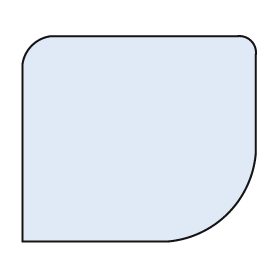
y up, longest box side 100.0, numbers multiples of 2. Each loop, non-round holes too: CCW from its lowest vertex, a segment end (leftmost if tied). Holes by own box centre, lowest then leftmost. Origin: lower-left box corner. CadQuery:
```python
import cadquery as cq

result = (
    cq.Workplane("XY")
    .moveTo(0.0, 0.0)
    .lineTo(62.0, 0.0)
    .threePointArc((88.0, 12.0), (100.0, 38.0))
    .lineTo(100.0, 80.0)
    .threePointArc((98.0, 86.0), (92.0, 88.0))
    .lineTo(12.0, 88.0)
    .threePointArc((4.0, 84.0), (0.0, 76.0))
    .close()
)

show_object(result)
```